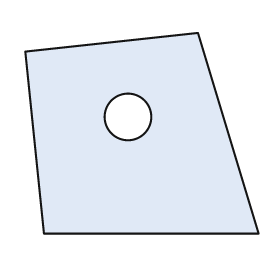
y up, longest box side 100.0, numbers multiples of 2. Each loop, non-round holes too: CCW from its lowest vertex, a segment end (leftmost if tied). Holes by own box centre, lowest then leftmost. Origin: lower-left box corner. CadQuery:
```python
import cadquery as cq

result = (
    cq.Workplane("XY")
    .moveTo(8.0, 0.0)
    .lineTo(100.0, 0.0)
    .lineTo(74.0, 86.0)
    .lineTo(0.0, 78.0)
    .close()
    .moveTo(44.0, 50.0)
    .circle(10.0)
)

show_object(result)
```